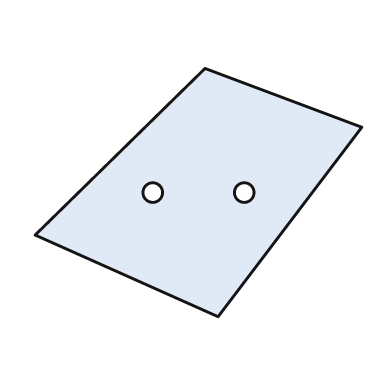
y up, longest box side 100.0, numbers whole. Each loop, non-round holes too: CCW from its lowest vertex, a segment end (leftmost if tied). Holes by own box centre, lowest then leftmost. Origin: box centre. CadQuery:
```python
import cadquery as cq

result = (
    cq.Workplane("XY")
    .moveTo(6.0, -38.0)
    .lineTo(50.0, 20.0)
    .lineTo(2.0, 38.0)
    .lineTo(-50.0, -13.0)
    .close()
    .moveTo(-14.0, 0.0)
    .circle(3.0)
    .moveTo(14.0, 0.0)
    .circle(3.0)
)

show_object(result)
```